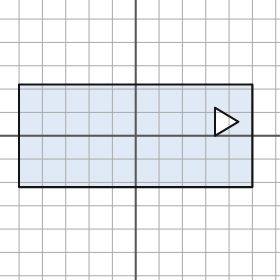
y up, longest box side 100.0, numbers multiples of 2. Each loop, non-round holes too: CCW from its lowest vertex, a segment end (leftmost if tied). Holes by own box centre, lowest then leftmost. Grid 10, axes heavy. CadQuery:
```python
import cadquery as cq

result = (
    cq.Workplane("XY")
    .moveTo(-50.0, -22.0)
    .lineTo(50.0, -22.0)
    .lineTo(50.0, 22.0)
    .lineTo(-50.0, 22.0)
    .close()
    .moveTo(34.0, 0.0)
    .lineTo(44.0, 6.0)
    .lineTo(34.0, 12.0)
    .close()
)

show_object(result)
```